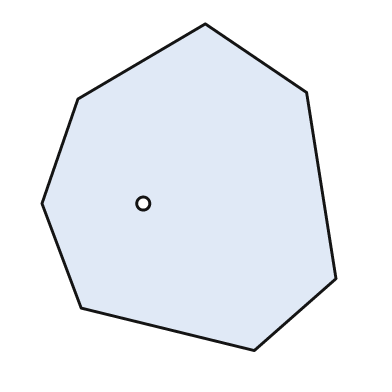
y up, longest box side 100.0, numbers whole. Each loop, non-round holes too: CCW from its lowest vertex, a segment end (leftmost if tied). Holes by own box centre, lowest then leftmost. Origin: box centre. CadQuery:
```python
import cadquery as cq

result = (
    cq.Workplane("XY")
    .moveTo(20.0, -50.0)
    .lineTo(45.0, -28.0)
    .lineTo(36.0, 29.0)
    .lineTo(5.0, 50.0)
    .lineTo(-34.0, 27.0)
    .lineTo(-45.0, -5.0)
    .lineTo(-33.0, -37.0)
    .close()
    .moveTo(-14.0, -5.0)
    .circle(2.0)
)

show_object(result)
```